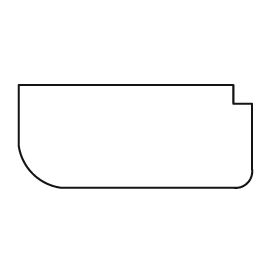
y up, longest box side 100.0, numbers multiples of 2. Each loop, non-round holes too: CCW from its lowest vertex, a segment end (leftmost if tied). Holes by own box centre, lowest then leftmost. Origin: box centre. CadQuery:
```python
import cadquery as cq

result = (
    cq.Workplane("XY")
    .moveTo(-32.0, -22.0)
    .lineTo(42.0, -22.0)
    .threePointArc((48.0, -20.0), (50.0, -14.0))
    .lineTo(50.0, 14.0)
    .lineTo(42.0, 14.0)
    .lineTo(42.0, 22.0)
    .lineTo(-50.0, 22.0)
    .lineTo(-50.0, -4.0)
    .threePointArc((-44.0, -16.0), (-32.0, -22.0))
    .close()
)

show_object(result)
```